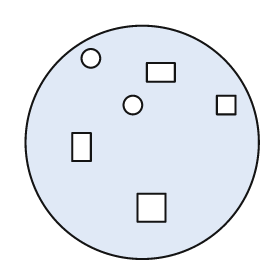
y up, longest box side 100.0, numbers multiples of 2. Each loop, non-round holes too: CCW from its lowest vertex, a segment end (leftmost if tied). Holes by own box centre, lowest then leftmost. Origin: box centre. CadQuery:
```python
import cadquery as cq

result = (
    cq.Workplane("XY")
    .moveTo(0.0, 0.0)
    .circle(50.0)
    .moveTo(-2.0, -34.0)
    .lineTo(10.0, -34.0)
    .lineTo(10.0, -22.0)
    .lineTo(-2.0, -22.0)
    .close()
    .moveTo(-30.0, -8.0)
    .lineTo(-22.0, -8.0)
    .lineTo(-22.0, 4.0)
    .lineTo(-30.0, 4.0)
    .close()
    .moveTo(-4.0, 16.0)
    .circle(4.0)
    .moveTo(32.0, 12.0)
    .lineTo(40.0, 12.0)
    .lineTo(40.0, 20.0)
    .lineTo(32.0, 20.0)
    .close()
    .moveTo(2.0, 26.0)
    .lineTo(14.0, 26.0)
    .lineTo(14.0, 34.0)
    .lineTo(2.0, 34.0)
    .close()
    .moveTo(-22.0, 36.0)
    .circle(4.0)
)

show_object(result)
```